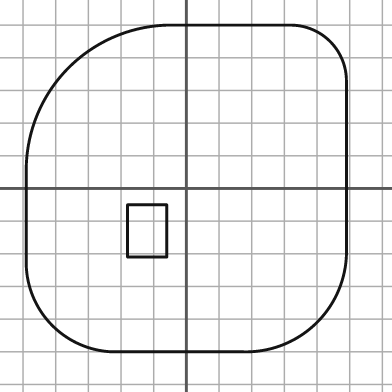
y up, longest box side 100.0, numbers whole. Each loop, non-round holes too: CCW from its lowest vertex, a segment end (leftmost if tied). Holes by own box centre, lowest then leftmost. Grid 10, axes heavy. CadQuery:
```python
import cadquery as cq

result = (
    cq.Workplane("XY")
    .moveTo(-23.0, -50.0)
    .lineTo(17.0, -50.0)
    .threePointArc((40.0, -41.0), (49.0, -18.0))
    .lineTo(49.0, 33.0)
    .threePointArc((44.0, 45.0), (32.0, 50.0))
    .lineTo(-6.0, 50.0)
    .threePointArc((-36.0, 37.0), (-49.0, 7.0))
    .lineTo(-49.0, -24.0)
    .threePointArc((-41.0, -42.0), (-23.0, -50.0))
    .close()
    .moveTo(-18.0, -21.0)
    .lineTo(-6.0, -21.0)
    .lineTo(-6.0, -5.0)
    .lineTo(-18.0, -5.0)
    .close()
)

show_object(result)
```